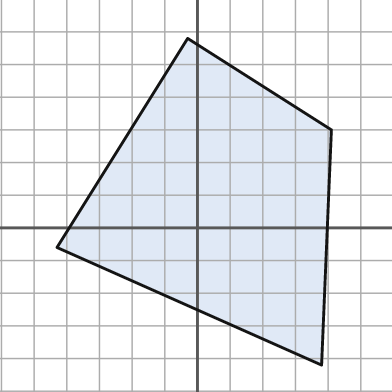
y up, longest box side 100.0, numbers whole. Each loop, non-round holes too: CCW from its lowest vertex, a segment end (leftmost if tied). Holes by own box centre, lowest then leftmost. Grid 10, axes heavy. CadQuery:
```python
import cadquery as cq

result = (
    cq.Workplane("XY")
    .moveTo(38.0, -42.0)
    .lineTo(41.0, 30.0)
    .lineTo(-3.0, 58.0)
    .lineTo(-43.0, -6.0)
    .close()
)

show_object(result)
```